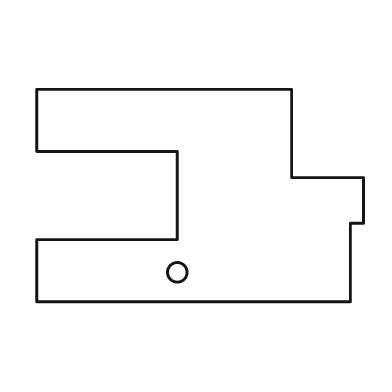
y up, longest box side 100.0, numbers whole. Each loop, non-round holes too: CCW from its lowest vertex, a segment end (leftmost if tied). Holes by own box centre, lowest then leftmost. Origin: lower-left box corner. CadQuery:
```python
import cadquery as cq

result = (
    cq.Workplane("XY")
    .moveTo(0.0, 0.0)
    .lineTo(96.0, 0.0)
    .lineTo(96.0, 24.0)
    .lineTo(100.0, 24.0)
    .lineTo(100.0, 38.0)
    .lineTo(78.0, 38.0)
    .lineTo(78.0, 65.0)
    .lineTo(0.0, 65.0)
    .lineTo(0.0, 46.0)
    .lineTo(43.0, 46.0)
    .lineTo(43.0, 19.0)
    .lineTo(0.0, 19.0)
    .close()
    .moveTo(43.0, 9.0)
    .circle(3.0)
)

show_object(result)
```